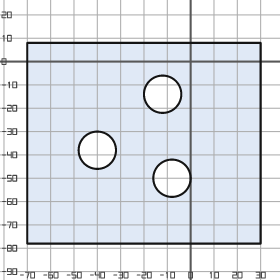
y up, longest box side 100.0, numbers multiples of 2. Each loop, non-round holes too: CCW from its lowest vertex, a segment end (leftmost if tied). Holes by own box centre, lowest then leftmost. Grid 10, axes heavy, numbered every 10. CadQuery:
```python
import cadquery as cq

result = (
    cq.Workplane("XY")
    .moveTo(-70.0, -78.0)
    .lineTo(30.0, -78.0)
    .lineTo(30.0, 8.0)
    .lineTo(-70.0, 8.0)
    .close()
    .moveTo(-8.0, -50.0)
    .circle(8.0)
    .moveTo(-40.0, -38.0)
    .circle(8.0)
    .moveTo(-12.0, -14.0)
    .circle(8.0)
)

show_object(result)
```